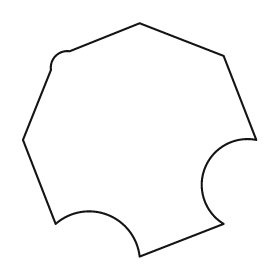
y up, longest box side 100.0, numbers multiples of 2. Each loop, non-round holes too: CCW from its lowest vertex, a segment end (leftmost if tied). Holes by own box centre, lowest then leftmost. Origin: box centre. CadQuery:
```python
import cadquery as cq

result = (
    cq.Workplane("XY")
    .moveTo(0.0, -50.0)
    .lineTo(36.0, -36.0)
    .threePointArc((28.0, -12.0), (50.0, 0.0))
    .lineTo(36.0, 36.0)
    .lineTo(0.0, 50.0)
    .lineTo(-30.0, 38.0)
    .threePointArc((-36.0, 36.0), (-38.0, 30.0))
    .lineTo(-50.0, 0.0)
    .lineTo(-36.0, -36.0)
    .threePointArc((-14.0, -32.0), (0.0, -50.0))
    .close()
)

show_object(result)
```